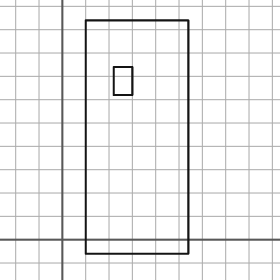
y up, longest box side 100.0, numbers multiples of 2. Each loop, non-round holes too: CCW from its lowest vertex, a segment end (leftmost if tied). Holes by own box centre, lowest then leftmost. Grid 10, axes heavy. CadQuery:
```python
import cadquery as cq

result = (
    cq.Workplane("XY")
    .moveTo(10.0, -6.0)
    .lineTo(54.0, -6.0)
    .lineTo(54.0, 94.0)
    .lineTo(10.0, 94.0)
    .close()
    .moveTo(22.0, 62.0)
    .lineTo(30.0, 62.0)
    .lineTo(30.0, 74.0)
    .lineTo(22.0, 74.0)
    .close()
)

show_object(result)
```